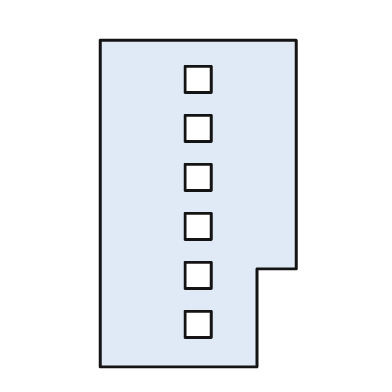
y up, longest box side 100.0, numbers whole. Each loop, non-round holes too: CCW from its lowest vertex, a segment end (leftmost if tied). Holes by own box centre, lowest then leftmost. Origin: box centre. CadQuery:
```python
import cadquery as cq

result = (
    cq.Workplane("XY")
    .moveTo(-30.0, -50.0)
    .lineTo(18.0, -50.0)
    .lineTo(18.0, -20.0)
    .lineTo(30.0, -20.0)
    .lineTo(30.0, 50.0)
    .lineTo(-30.0, 50.0)
    .close()
    .moveTo(-4.0, -41.0)
    .lineTo(4.0, -41.0)
    .lineTo(4.0, -33.0)
    .lineTo(-4.0, -33.0)
    .close()
    .moveTo(-4.0, -26.0)
    .lineTo(4.0, -26.0)
    .lineTo(4.0, -18.0)
    .lineTo(-4.0, -18.0)
    .close()
    .moveTo(-4.0, -11.0)
    .lineTo(4.0, -11.0)
    .lineTo(4.0, -3.0)
    .lineTo(-4.0, -3.0)
    .close()
    .moveTo(-4.0, 4.0)
    .lineTo(4.0, 4.0)
    .lineTo(4.0, 12.0)
    .lineTo(-4.0, 12.0)
    .close()
    .moveTo(-4.0, 19.0)
    .lineTo(4.0, 19.0)
    .lineTo(4.0, 27.0)
    .lineTo(-4.0, 27.0)
    .close()
    .moveTo(-4.0, 34.0)
    .lineTo(4.0, 34.0)
    .lineTo(4.0, 42.0)
    .lineTo(-4.0, 42.0)
    .close()
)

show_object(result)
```